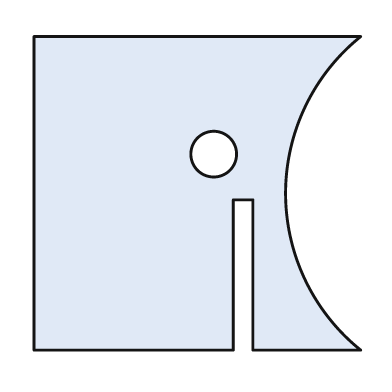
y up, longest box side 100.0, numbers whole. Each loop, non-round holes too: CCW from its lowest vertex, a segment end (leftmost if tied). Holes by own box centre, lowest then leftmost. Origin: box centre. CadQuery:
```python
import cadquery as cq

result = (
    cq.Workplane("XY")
    .moveTo(-50.0, -48.0)
    .lineTo(11.0, -48.0)
    .lineTo(11.0, -2.0)
    .lineTo(17.0, -2.0)
    .lineTo(17.0, -48.0)
    .lineTo(50.0, -48.0)
    .threePointArc((27.0, 0.0), (50.0, 48.0))
    .lineTo(-50.0, 48.0)
    .close()
    .moveTo(5.0, 12.0)
    .circle(7.0)
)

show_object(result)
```